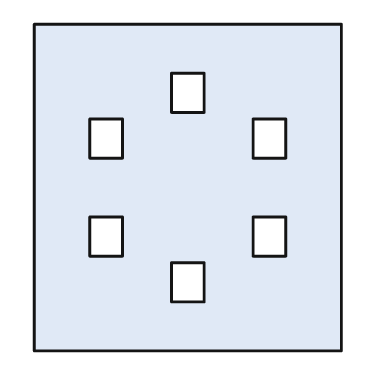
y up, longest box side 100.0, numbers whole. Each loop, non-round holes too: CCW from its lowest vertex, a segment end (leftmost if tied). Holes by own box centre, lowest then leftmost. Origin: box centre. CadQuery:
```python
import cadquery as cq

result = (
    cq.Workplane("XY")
    .moveTo(-47.0, -50.0)
    .lineTo(47.0, -50.0)
    .lineTo(47.0, 50.0)
    .lineTo(-47.0, 50.0)
    .close()
    .moveTo(-5.0, -35.0)
    .lineTo(5.0, -35.0)
    .lineTo(5.0, -23.0)
    .lineTo(-5.0, -23.0)
    .close()
    .moveTo(-30.0, -21.0)
    .lineTo(-20.0, -21.0)
    .lineTo(-20.0, -9.0)
    .lineTo(-30.0, -9.0)
    .close()
    .moveTo(20.0, -21.0)
    .lineTo(30.0, -21.0)
    .lineTo(30.0, -9.0)
    .lineTo(20.0, -9.0)
    .close()
    .moveTo(-30.0, 9.0)
    .lineTo(-20.0, 9.0)
    .lineTo(-20.0, 21.0)
    .lineTo(-30.0, 21.0)
    .close()
    .moveTo(20.0, 9.0)
    .lineTo(30.0, 9.0)
    .lineTo(30.0, 21.0)
    .lineTo(20.0, 21.0)
    .close()
    .moveTo(-5.0, 23.0)
    .lineTo(5.0, 23.0)
    .lineTo(5.0, 35.0)
    .lineTo(-5.0, 35.0)
    .close()
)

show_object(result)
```